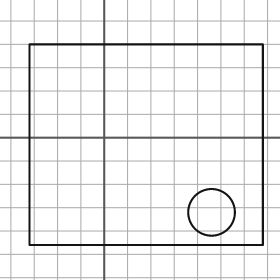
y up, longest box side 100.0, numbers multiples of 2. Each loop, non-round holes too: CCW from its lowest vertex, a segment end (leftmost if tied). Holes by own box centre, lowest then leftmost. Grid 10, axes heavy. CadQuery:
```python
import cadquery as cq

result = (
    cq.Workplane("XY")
    .moveTo(-32.0, -46.0)
    .lineTo(68.0, -46.0)
    .lineTo(68.0, 40.0)
    .lineTo(-32.0, 40.0)
    .close()
    .moveTo(46.0, -32.0)
    .circle(10.0)
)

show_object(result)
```